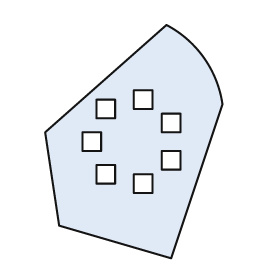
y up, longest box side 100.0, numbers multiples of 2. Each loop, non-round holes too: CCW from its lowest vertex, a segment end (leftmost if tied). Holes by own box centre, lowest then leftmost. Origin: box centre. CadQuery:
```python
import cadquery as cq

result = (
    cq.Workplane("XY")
    .moveTo(16.0, -50.0)
    .lineTo(38.0, 16.0)
    .threePointArc((30.0, 36.0), (14.0, 50.0))
    .lineTo(-38.0, 4.0)
    .lineTo(-32.0, -36.0)
    .close()
    .moveTo(0.0, -22.0)
    .lineTo(8.0, -22.0)
    .lineTo(8.0, -14.0)
    .lineTo(0.0, -14.0)
    .close()
    .moveTo(-16.0, -18.0)
    .lineTo(-8.0, -18.0)
    .lineTo(-8.0, -10.0)
    .lineTo(-16.0, -10.0)
    .close()
    .moveTo(12.0, -12.0)
    .lineTo(20.0, -12.0)
    .lineTo(20.0, -4.0)
    .lineTo(12.0, -4.0)
    .close()
    .moveTo(-22.0, -4.0)
    .lineTo(-14.0, -4.0)
    .lineTo(-14.0, 4.0)
    .lineTo(-22.0, 4.0)
    .close()
    .moveTo(12.0, 4.0)
    .lineTo(20.0, 4.0)
    .lineTo(20.0, 12.0)
    .lineTo(12.0, 12.0)
    .close()
    .moveTo(-16.0, 10.0)
    .lineTo(-8.0, 10.0)
    .lineTo(-8.0, 18.0)
    .lineTo(-16.0, 18.0)
    .close()
    .moveTo(0.0, 14.0)
    .lineTo(8.0, 14.0)
    .lineTo(8.0, 22.0)
    .lineTo(0.0, 22.0)
    .close()
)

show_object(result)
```